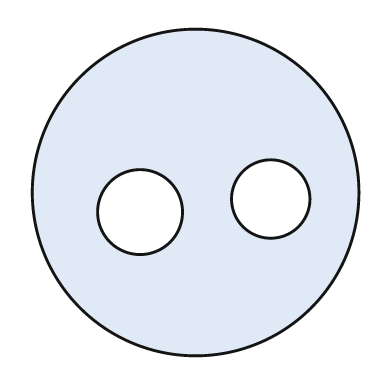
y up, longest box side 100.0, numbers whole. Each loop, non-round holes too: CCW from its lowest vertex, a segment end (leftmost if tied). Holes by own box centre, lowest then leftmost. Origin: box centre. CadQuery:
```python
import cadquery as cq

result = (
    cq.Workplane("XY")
    .moveTo(0.0, 0.0)
    .circle(50.0)
    .moveTo(-17.0, -6.0)
    .circle(13.0)
    .moveTo(23.0, -2.0)
    .circle(12.0)
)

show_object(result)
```